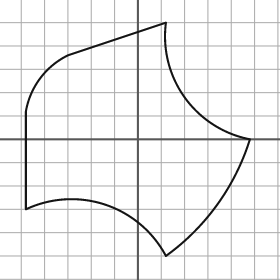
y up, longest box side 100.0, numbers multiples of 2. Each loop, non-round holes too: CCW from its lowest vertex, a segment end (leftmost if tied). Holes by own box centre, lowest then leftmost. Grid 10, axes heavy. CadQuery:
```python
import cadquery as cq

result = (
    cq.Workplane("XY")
    .moveTo(12.0, -50.0)
    .threePointArc((34.0, -28.0), (48.0, 0.0))
    .threePointArc((20.0, 18.0), (12.0, 50.0))
    .lineTo(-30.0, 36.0)
    .threePointArc((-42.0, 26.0), (-48.0, 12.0))
    .lineTo(-48.0, -30.0)
    .threePointArc((-14.0, -28.0), (12.0, -50.0))
    .close()
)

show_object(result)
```